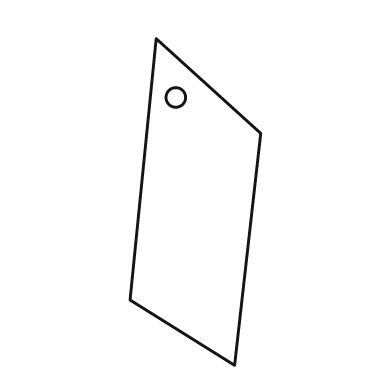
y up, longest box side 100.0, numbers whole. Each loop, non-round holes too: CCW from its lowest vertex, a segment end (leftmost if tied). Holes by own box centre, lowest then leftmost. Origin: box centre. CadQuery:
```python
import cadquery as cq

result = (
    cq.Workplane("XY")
    .moveTo(12.0, -50.0)
    .lineTo(20.0, 21.0)
    .lineTo(-12.0, 50.0)
    .lineTo(-20.0, -30.0)
    .close()
    .moveTo(-6.0, 32.0)
    .circle(3.0)
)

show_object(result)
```